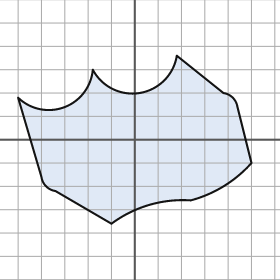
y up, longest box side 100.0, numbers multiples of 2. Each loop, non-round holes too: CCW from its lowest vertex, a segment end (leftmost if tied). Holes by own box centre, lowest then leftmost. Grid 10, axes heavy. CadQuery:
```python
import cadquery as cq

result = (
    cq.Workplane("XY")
    .moveTo(-10.0, -36.0)
    .threePointArc((6.0, -28.0), (24.0, -26.0))
    .threePointArc((38.0, -20.0), (50.0, -10.0))
    .lineTo(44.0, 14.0)
    .threePointArc((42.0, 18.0), (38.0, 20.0))
    .lineTo(18.0, 36.0)
    .threePointArc((2.0, 20.0), (-18.0, 30.0))
    .threePointArc((-30.0, 14.0), (-50.0, 18.0))
    .lineTo(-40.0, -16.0)
    .threePointArc((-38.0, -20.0), (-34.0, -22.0))
    .close()
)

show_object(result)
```